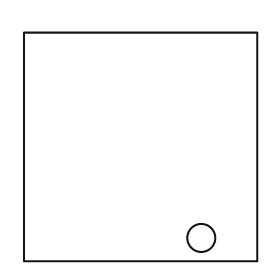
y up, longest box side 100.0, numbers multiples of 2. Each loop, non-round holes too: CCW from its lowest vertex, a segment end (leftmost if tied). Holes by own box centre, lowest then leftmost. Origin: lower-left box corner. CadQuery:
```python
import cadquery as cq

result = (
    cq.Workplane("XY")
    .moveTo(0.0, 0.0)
    .lineTo(100.0, 0.0)
    .lineTo(100.0, 98.0)
    .lineTo(0.0, 98.0)
    .close()
    .moveTo(76.0, 10.0)
    .circle(6.0)
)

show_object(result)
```